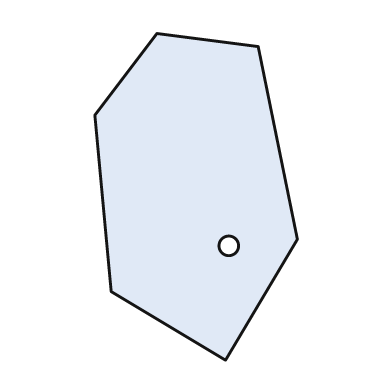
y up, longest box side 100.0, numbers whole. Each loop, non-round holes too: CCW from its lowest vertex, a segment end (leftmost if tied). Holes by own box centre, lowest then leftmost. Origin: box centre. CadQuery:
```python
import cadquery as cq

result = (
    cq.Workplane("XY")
    .moveTo(9.0, -50.0)
    .lineTo(31.0, -13.0)
    .lineTo(19.0, 46.0)
    .lineTo(-12.0, 50.0)
    .lineTo(-31.0, 25.0)
    .lineTo(-26.0, -29.0)
    .close()
    .moveTo(10.0, -15.0)
    .circle(3.0)
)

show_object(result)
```